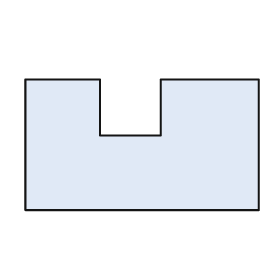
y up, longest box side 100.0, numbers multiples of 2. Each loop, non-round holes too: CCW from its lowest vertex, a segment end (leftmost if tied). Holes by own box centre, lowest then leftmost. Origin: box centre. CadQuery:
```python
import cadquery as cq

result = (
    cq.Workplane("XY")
    .moveTo(-50.0, -28.0)
    .lineTo(50.0, -28.0)
    .lineTo(50.0, 28.0)
    .lineTo(8.0, 28.0)
    .lineTo(8.0, 4.0)
    .lineTo(-18.0, 4.0)
    .lineTo(-18.0, 28.0)
    .lineTo(-50.0, 28.0)
    .close()
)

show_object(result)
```